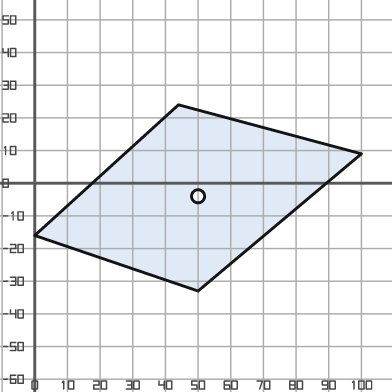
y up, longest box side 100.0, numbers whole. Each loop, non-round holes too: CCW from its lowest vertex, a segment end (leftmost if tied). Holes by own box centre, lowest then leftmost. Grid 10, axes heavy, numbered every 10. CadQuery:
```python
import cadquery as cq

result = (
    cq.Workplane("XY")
    .moveTo(50.0, -33.0)
    .lineTo(100.0, 9.0)
    .lineTo(44.0, 24.0)
    .lineTo(0.0, -16.0)
    .close()
    .moveTo(50.0, -4.0)
    .circle(2.0)
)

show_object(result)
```